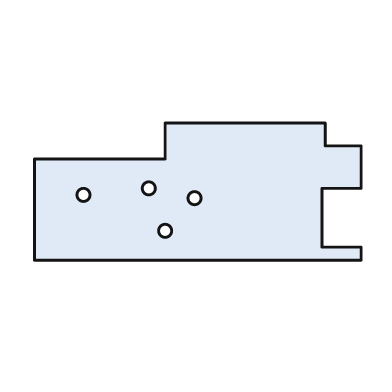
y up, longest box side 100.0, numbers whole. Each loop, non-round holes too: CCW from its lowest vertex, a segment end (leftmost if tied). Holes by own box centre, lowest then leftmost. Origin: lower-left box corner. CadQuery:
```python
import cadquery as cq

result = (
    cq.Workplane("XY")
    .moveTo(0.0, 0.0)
    .lineTo(100.0, 0.0)
    .lineTo(100.0, 4.0)
    .lineTo(88.0, 4.0)
    .lineTo(88.0, 22.0)
    .lineTo(100.0, 22.0)
    .lineTo(100.0, 35.0)
    .lineTo(89.0, 35.0)
    .lineTo(89.0, 42.0)
    .lineTo(40.0, 42.0)
    .lineTo(40.0, 31.0)
    .lineTo(0.0, 31.0)
    .close()
    .moveTo(40.0, 9.0)
    .circle(2.0)
    .moveTo(49.0, 19.0)
    .circle(2.0)
    .moveTo(15.0, 20.0)
    .circle(2.0)
    .moveTo(35.0, 22.0)
    .circle(2.0)
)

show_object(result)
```